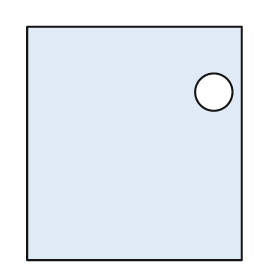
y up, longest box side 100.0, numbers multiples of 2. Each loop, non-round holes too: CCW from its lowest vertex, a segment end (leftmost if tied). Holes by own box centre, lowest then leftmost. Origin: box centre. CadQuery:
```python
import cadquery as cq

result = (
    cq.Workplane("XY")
    .moveTo(-46.0, -50.0)
    .lineTo(46.0, -50.0)
    .lineTo(46.0, 50.0)
    .lineTo(-46.0, 50.0)
    .close()
    .moveTo(34.0, 22.0)
    .circle(8.0)
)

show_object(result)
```